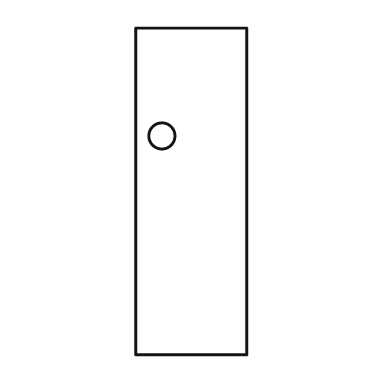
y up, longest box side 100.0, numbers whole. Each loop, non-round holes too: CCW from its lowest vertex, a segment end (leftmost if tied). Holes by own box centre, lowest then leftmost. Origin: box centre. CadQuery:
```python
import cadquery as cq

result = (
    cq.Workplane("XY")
    .moveTo(-17.0, -50.0)
    .lineTo(17.0, -50.0)
    .lineTo(17.0, 50.0)
    .lineTo(-17.0, 50.0)
    .close()
    .moveTo(-9.0, 17.0)
    .circle(4.0)
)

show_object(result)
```